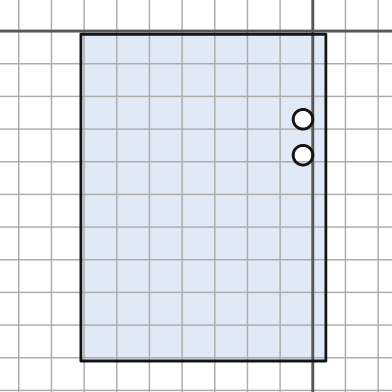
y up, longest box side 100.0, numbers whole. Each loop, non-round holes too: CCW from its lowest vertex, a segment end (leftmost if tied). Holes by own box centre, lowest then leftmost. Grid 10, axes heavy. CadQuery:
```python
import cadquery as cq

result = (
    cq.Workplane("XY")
    .moveTo(-71.0, -101.0)
    .lineTo(4.0, -101.0)
    .lineTo(4.0, -1.0)
    .lineTo(-71.0, -1.0)
    .close()
    .moveTo(-3.0, -38.0)
    .circle(3.0)
    .moveTo(-3.0, -27.0)
    .circle(3.0)
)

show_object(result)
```